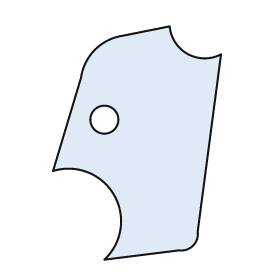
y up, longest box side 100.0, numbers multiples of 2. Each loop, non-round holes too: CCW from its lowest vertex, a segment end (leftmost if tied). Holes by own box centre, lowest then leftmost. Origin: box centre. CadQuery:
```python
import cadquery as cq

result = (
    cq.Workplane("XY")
    .moveTo(-14.0, -50.0)
    .lineTo(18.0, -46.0)
    .threePointArc((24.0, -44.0), (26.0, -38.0))
    .lineTo(36.0, 38.0)
    .threePointArc((22.0, 38.0), (14.0, 50.0))
    .lineTo(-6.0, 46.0)
    .threePointArc((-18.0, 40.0), (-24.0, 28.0))
    .lineTo(-36.0, -12.0)
    .threePointArc((-10.0, -22.0), (-14.0, -50.0))
    .close()
    .moveTo(-14.0, 10.0)
    .circle(6.0)
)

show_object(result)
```